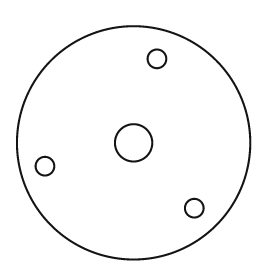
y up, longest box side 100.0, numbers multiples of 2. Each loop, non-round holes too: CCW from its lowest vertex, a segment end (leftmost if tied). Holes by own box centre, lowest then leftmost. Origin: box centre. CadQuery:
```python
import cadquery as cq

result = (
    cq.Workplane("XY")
    .moveTo(0.0, 0.0)
    .circle(50.0)
    .moveTo(26.0, -28.0)
    .circle(4.0)
    .moveTo(-38.0, -10.0)
    .circle(4.0)
    .moveTo(0.0, 0.0)
    .circle(8.0)
    .moveTo(10.0, 36.0)
    .circle(4.0)
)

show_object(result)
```